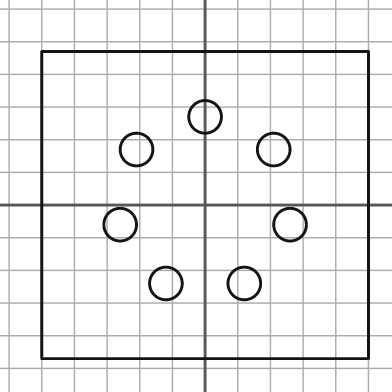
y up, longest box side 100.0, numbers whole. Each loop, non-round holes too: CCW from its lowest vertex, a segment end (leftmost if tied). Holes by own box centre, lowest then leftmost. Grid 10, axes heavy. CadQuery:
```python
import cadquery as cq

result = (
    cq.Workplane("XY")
    .moveTo(-50.0, -47.0)
    .lineTo(50.0, -47.0)
    .lineTo(50.0, 47.0)
    .lineTo(-50.0, 47.0)
    .close()
    .moveTo(-12.0, -24.0)
    .circle(5.0)
    .moveTo(12.0, -24.0)
    .circle(5.0)
    .moveTo(-26.0, -6.0)
    .circle(5.0)
    .moveTo(26.0, -6.0)
    .circle(5.0)
    .moveTo(-21.0, 17.0)
    .circle(5.0)
    .moveTo(21.0, 17.0)
    .circle(5.0)
    .moveTo(0.0, 27.0)
    .circle(5.0)
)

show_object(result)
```